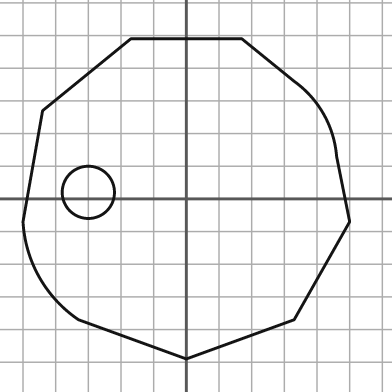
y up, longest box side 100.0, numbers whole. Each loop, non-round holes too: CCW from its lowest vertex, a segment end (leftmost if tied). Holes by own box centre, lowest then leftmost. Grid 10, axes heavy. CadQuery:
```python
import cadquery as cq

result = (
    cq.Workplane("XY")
    .moveTo(0.0, -49.0)
    .lineTo(33.0, -37.0)
    .lineTo(50.0, -7.0)
    .lineTo(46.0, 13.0)
    .threePointArc((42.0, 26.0), (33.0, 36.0))
    .lineTo(17.0, 49.0)
    .lineTo(-17.0, 49.0)
    .lineTo(-44.0, 27.0)
    .lineTo(-50.0, -7.0)
    .threePointArc((-45.0, -24.0), (-33.0, -37.0))
    .close()
    .moveTo(-30.0, 2.0)
    .circle(8.0)
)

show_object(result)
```